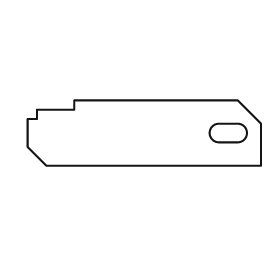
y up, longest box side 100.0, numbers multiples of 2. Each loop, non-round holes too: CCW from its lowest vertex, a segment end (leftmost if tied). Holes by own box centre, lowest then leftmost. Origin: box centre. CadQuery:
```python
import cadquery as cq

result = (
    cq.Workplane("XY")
    .moveTo(-42.0, -14.0)
    .lineTo(50.0, -14.0)
    .lineTo(50.0, 4.0)
    .lineTo(40.0, 14.0)
    .lineTo(-30.0, 14.0)
    .lineTo(-30.0, 10.0)
    .lineTo(-46.0, 10.0)
    .lineTo(-46.0, 6.0)
    .lineTo(-50.0, 6.0)
    .lineTo(-50.0, -6.0)
    .close()
    .moveTo(32.0, -4.0)
    .lineTo(40.0, -4.0)
    .threePointArc((44.0, 0.0), (40.0, 4.0))
    .lineTo(32.0, 4.0)
    .threePointArc((28.0, 0.0), (32.0, -4.0))
    .close()
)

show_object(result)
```